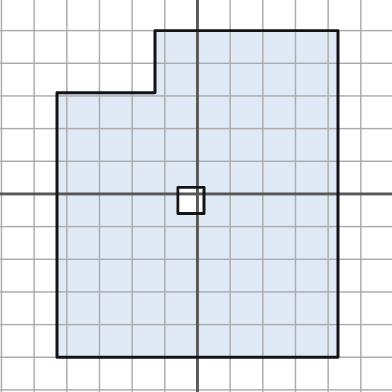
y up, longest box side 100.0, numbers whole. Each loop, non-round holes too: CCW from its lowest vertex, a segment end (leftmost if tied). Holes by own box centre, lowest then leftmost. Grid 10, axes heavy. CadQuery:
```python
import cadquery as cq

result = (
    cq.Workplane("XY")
    .moveTo(-43.0, -50.0)
    .lineTo(43.0, -50.0)
    .lineTo(43.0, 50.0)
    .lineTo(-13.0, 50.0)
    .lineTo(-13.0, 31.0)
    .lineTo(-43.0, 31.0)
    .close()
    .moveTo(-6.0, -6.0)
    .lineTo(2.0, -6.0)
    .lineTo(2.0, 2.0)
    .lineTo(-6.0, 2.0)
    .close()
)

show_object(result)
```